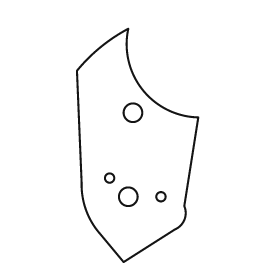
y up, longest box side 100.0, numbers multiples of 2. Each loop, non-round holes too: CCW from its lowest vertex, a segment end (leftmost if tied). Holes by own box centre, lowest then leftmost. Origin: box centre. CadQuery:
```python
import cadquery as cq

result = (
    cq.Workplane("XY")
    .moveTo(-6.0, -50.0)
    .lineTo(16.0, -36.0)
    .threePointArc((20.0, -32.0), (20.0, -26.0))
    .lineTo(26.0, 12.0)
    .threePointArc((2.0, 24.0), (-4.0, 50.0))
    .threePointArc((-16.0, 42.0), (-26.0, 32.0))
    .lineTo(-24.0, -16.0)
    .threePointArc((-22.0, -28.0), (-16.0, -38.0))
    .close()
    .moveTo(-4.0, -22.0)
    .circle(4.0)
    .moveTo(10.0, -22.0)
    .circle(2.0)
    .moveTo(-12.0, -14.0)
    .circle(2.0)
    .moveTo(-2.0, 14.0)
    .circle(4.0)
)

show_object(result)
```